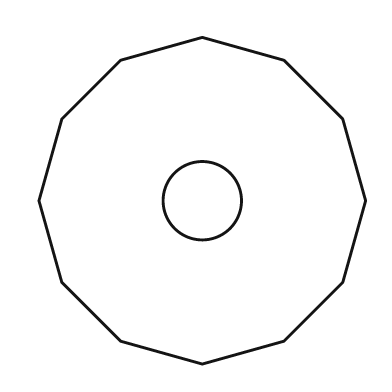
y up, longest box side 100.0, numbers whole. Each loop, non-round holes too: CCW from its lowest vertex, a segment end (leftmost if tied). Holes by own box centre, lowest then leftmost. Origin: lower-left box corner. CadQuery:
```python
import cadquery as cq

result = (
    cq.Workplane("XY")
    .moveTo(50.0, 0.0)
    .lineTo(75.0, 7.0)
    .lineTo(93.0, 25.0)
    .lineTo(100.0, 50.0)
    .lineTo(93.0, 75.0)
    .lineTo(75.0, 93.0)
    .lineTo(50.0, 100.0)
    .lineTo(25.0, 93.0)
    .lineTo(7.0, 75.0)
    .lineTo(0.0, 50.0)
    .lineTo(7.0, 25.0)
    .lineTo(25.0, 7.0)
    .close()
    .moveTo(50.0, 50.0)
    .circle(12.0)
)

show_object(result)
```